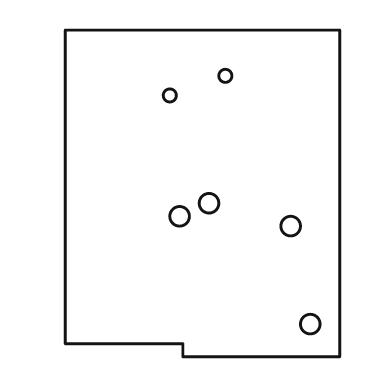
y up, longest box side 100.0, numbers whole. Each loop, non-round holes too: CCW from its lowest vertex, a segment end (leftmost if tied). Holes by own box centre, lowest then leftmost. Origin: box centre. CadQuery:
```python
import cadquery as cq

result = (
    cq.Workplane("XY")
    .moveTo(-6.0, -50.0)
    .lineTo(42.0, -50.0)
    .lineTo(42.0, 50.0)
    .lineTo(-42.0, 50.0)
    .lineTo(-42.0, -46.0)
    .lineTo(-6.0, -46.0)
    .close()
    .moveTo(33.0, -40.0)
    .circle(3.0)
    .moveTo(27.0, -10.0)
    .circle(3.0)
    .moveTo(-7.0, -7.0)
    .circle(3.0)
    .moveTo(2.0, -3.0)
    .circle(3.0)
    .moveTo(-10.0, 30.0)
    .circle(2.0)
    .moveTo(7.0, 36.0)
    .circle(2.0)
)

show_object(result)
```